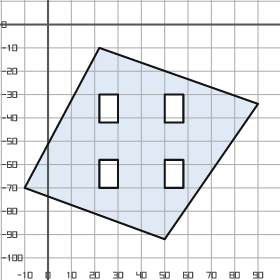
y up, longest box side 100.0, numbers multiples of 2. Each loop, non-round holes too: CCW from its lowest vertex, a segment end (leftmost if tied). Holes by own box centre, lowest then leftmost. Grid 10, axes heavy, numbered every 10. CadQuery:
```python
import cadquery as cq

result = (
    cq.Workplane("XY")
    .moveTo(50.0, -92.0)
    .lineTo(90.0, -34.0)
    .lineTo(22.0, -10.0)
    .lineTo(-10.0, -70.0)
    .close()
    .moveTo(22.0, -70.0)
    .lineTo(30.0, -70.0)
    .lineTo(30.0, -58.0)
    .lineTo(22.0, -58.0)
    .close()
    .moveTo(50.0, -70.0)
    .lineTo(58.0, -70.0)
    .lineTo(58.0, -58.0)
    .lineTo(50.0, -58.0)
    .close()
    .moveTo(22.0, -42.0)
    .lineTo(30.0, -42.0)
    .lineTo(30.0, -30.0)
    .lineTo(22.0, -30.0)
    .close()
    .moveTo(50.0, -42.0)
    .lineTo(58.0, -42.0)
    .lineTo(58.0, -30.0)
    .lineTo(50.0, -30.0)
    .close()
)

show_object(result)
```